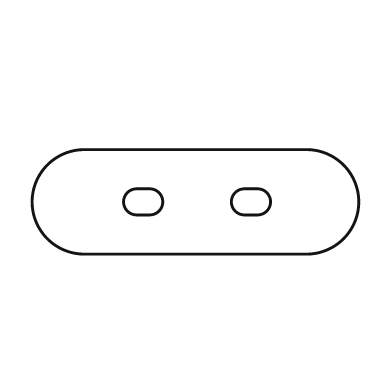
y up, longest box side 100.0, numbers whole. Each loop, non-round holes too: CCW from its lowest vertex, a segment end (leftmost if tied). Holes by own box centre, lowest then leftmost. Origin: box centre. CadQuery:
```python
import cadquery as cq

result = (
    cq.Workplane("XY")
    .moveTo(-34.0, -16.0)
    .lineTo(34.0, -16.0)
    .threePointArc((50.0, 0.0), (34.0, 16.0))
    .lineTo(-34.0, 16.0)
    .threePointArc((-50.0, 0.0), (-34.0, -16.0))
    .close()
    .moveTo(-18.0, -4.0)
    .lineTo(-14.0, -4.0)
    .threePointArc((-10.0, 0.0), (-14.0, 4.0))
    .lineTo(-18.0, 4.0)
    .threePointArc((-22.0, 0.0), (-18.0, -4.0))
    .close()
    .moveTo(15.0, -4.0)
    .lineTo(19.0, -4.0)
    .threePointArc((23.0, 0.0), (19.0, 4.0))
    .lineTo(15.0, 4.0)
    .threePointArc((11.0, 0.0), (15.0, -4.0))
    .close()
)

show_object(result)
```